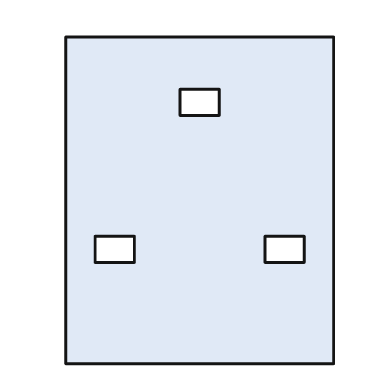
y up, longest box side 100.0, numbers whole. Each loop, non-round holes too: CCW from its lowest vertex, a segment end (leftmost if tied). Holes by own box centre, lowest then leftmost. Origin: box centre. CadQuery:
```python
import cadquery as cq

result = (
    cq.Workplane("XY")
    .moveTo(-41.0, -50.0)
    .lineTo(41.0, -50.0)
    .lineTo(41.0, 50.0)
    .lineTo(-41.0, 50.0)
    .close()
    .moveTo(-32.0, -19.0)
    .lineTo(-20.0, -19.0)
    .lineTo(-20.0, -11.0)
    .lineTo(-32.0, -11.0)
    .close()
    .moveTo(20.0, -19.0)
    .lineTo(32.0, -19.0)
    .lineTo(32.0, -11.0)
    .lineTo(20.0, -11.0)
    .close()
    .moveTo(-6.0, 26.0)
    .lineTo(6.0, 26.0)
    .lineTo(6.0, 34.0)
    .lineTo(-6.0, 34.0)
    .close()
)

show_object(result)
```